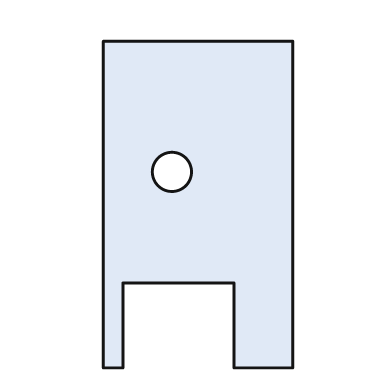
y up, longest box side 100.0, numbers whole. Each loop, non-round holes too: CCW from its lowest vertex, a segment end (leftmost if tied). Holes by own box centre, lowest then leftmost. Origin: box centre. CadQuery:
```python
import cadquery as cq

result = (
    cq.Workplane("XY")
    .moveTo(-29.0, -50.0)
    .lineTo(-23.0, -50.0)
    .lineTo(-23.0, -24.0)
    .lineTo(11.0, -24.0)
    .lineTo(11.0, -50.0)
    .lineTo(29.0, -50.0)
    .lineTo(29.0, 50.0)
    .lineTo(-29.0, 50.0)
    .close()
    .moveTo(-8.0, 10.0)
    .circle(6.0)
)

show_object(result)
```